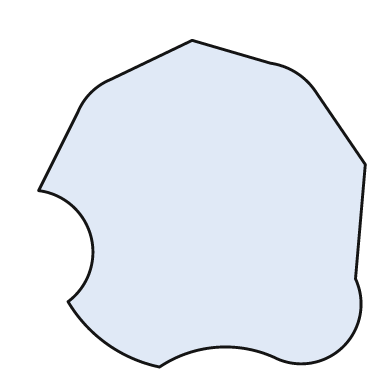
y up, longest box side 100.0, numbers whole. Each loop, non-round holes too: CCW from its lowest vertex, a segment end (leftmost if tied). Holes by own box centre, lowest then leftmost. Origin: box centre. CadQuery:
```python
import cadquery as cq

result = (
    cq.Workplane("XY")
    .moveTo(-13.0, -50.0)
    .threePointArc((4.0, -44.0), (22.0, -47.0))
    .threePointArc((43.0, -44.0), (47.0, -23.0))
    .lineTo(50.0, 12.0)
    .lineTo(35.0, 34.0)
    .threePointArc((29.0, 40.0), (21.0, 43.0))
    .lineTo(-3.0, 50.0)
    .lineTo(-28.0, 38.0)
    .threePointArc((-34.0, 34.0), (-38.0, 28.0))
    .lineTo(-50.0, 4.0)
    .threePointArc((-34.0, -10.0), (-41.0, -30.0))
    .threePointArc((-29.0, -43.0), (-13.0, -50.0))
    .close()
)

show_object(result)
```